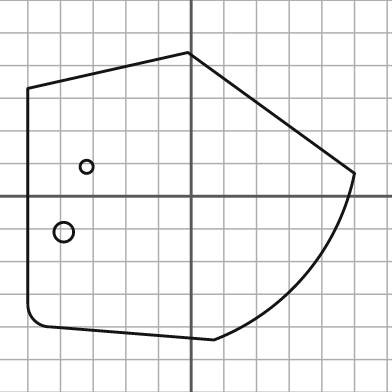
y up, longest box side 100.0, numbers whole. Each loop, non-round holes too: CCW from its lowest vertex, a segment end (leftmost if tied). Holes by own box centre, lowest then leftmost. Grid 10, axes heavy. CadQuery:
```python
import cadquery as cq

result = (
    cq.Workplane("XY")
    .moveTo(7.0, -44.0)
    .threePointArc((35.0, -24.0), (50.0, 7.0))
    .lineTo(-1.0, 44.0)
    .lineTo(-50.0, 33.0)
    .lineTo(-50.0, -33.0)
    .threePointArc((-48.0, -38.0), (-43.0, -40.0))
    .close()
    .moveTo(-39.0, -11.0)
    .circle(3.0)
    .moveTo(-32.0, 9.0)
    .circle(2.0)
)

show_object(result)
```